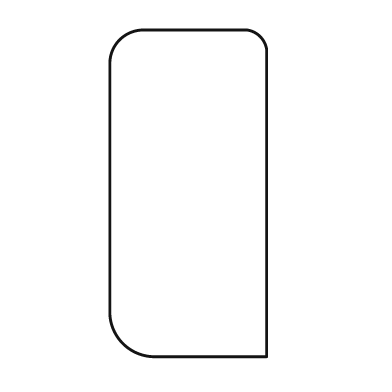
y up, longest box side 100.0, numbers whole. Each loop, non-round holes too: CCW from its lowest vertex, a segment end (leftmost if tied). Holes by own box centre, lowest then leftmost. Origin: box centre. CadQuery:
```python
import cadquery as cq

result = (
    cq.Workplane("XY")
    .moveTo(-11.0, -50.0)
    .lineTo(24.0, -50.0)
    .lineTo(24.0, 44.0)
    .threePointArc((22.0, 48.0), (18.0, 50.0))
    .lineTo(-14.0, 50.0)
    .threePointArc((-21.0, 47.0), (-24.0, 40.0))
    .lineTo(-24.0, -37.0)
    .threePointArc((-20.0, -46.0), (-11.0, -50.0))
    .close()
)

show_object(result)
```